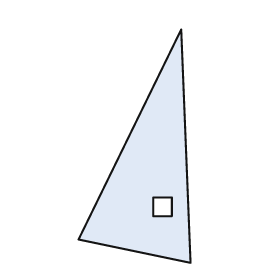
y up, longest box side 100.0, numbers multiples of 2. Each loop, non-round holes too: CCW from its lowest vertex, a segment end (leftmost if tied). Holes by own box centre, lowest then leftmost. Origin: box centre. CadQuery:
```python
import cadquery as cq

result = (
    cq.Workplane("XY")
    .moveTo(24.0, -50.0)
    .lineTo(20.0, 50.0)
    .lineTo(-24.0, -40.0)
    .close()
    .moveTo(8.0, -30.0)
    .lineTo(16.0, -30.0)
    .lineTo(16.0, -22.0)
    .lineTo(8.0, -22.0)
    .close()
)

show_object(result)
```